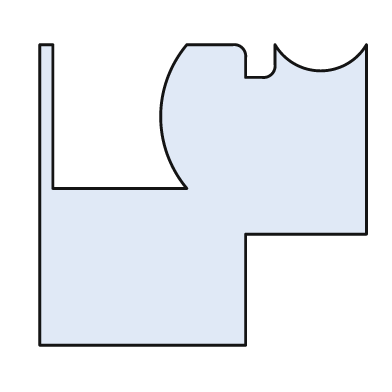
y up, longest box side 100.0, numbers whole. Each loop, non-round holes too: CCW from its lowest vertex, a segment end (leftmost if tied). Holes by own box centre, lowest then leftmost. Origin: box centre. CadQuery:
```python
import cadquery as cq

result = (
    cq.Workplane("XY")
    .moveTo(-50.0, -46.0)
    .lineTo(13.0, -46.0)
    .lineTo(13.0, -12.0)
    .lineTo(50.0, -12.0)
    .lineTo(50.0, 46.0)
    .threePointArc((36.0, 38.0), (22.0, 46.0))
    .lineTo(22.0, 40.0)
    .threePointArc((21.0, 37.0), (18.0, 36.0))
    .lineTo(13.0, 36.0)
    .lineTo(13.0, 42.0)
    .threePointArc((12.0, 45.0), (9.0, 46.0))
    .lineTo(-5.0, 46.0)
    .threePointArc((-13.0, 24.0), (-5.0, 2.0))
    .lineTo(-46.0, 2.0)
    .lineTo(-46.0, 46.0)
    .lineTo(-50.0, 46.0)
    .close()
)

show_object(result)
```